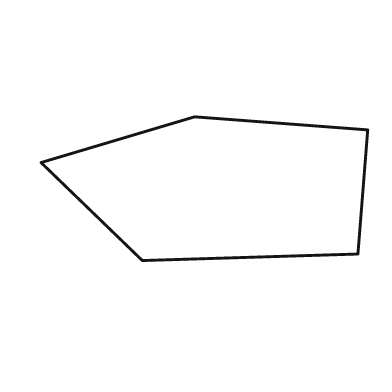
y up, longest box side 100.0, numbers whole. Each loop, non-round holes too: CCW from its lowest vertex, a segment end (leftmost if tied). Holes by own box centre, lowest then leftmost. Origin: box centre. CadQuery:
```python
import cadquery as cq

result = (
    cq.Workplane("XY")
    .moveTo(-19.0, -22.0)
    .lineTo(47.0, -20.0)
    .lineTo(50.0, 18.0)
    .lineTo(-3.0, 22.0)
    .lineTo(-50.0, 8.0)
    .close()
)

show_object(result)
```